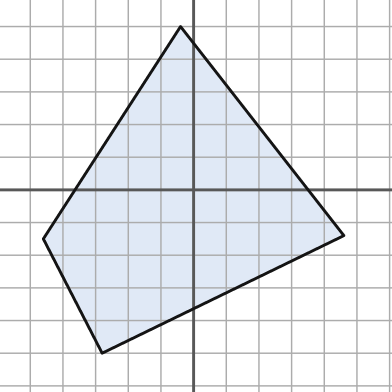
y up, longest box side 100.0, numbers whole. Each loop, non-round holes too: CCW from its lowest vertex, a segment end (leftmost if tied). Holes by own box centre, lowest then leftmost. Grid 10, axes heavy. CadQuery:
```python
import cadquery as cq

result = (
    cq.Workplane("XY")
    .moveTo(-28.0, -50.0)
    .lineTo(46.0, -14.0)
    .lineTo(-4.0, 50.0)
    .lineTo(-46.0, -15.0)
    .close()
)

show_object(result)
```